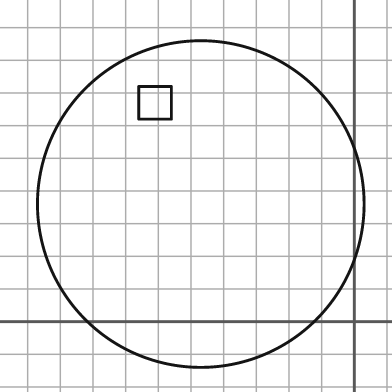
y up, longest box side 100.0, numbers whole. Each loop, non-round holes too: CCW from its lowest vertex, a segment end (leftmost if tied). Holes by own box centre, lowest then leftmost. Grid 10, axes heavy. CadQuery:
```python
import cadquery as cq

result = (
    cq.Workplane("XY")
    .moveTo(-47.0, 36.0)
    .circle(50.0)
    .moveTo(-66.0, 62.0)
    .lineTo(-56.0, 62.0)
    .lineTo(-56.0, 72.0)
    .lineTo(-66.0, 72.0)
    .close()
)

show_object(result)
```